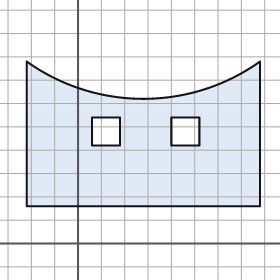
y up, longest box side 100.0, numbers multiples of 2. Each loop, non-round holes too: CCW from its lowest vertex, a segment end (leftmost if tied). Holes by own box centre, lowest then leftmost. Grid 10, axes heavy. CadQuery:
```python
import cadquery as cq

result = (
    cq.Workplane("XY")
    .moveTo(-22.0, 16.0)
    .lineTo(78.0, 16.0)
    .lineTo(78.0, 78.0)
    .threePointArc((28.0, 62.0), (-22.0, 78.0))
    .close()
    .moveTo(6.0, 42.0)
    .lineTo(18.0, 42.0)
    .lineTo(18.0, 54.0)
    .lineTo(6.0, 54.0)
    .close()
    .moveTo(40.0, 42.0)
    .lineTo(52.0, 42.0)
    .lineTo(52.0, 54.0)
    .lineTo(40.0, 54.0)
    .close()
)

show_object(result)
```